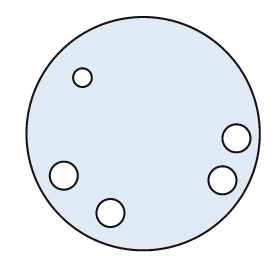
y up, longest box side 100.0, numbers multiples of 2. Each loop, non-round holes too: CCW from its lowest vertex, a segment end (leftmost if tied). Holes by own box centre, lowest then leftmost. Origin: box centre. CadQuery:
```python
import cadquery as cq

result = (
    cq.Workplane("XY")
    .moveTo(0.0, 0.0)
    .circle(50.0)
    .moveTo(-14.0, -34.0)
    .circle(6.0)
    .moveTo(34.0, -20.0)
    .circle(6.0)
    .moveTo(-34.0, -18.0)
    .circle(6.0)
    .moveTo(40.0, -2.0)
    .circle(6.0)
    .moveTo(-26.0, 24.0)
    .circle(4.0)
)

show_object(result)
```